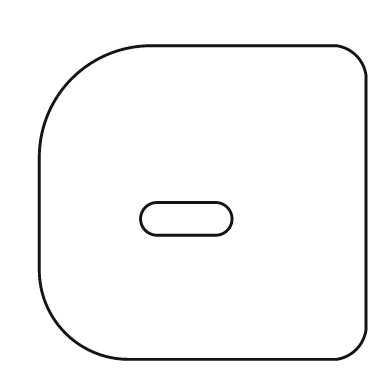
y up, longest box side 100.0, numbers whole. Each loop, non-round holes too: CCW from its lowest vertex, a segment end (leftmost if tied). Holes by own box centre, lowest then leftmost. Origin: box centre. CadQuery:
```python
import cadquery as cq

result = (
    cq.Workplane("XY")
    .moveTo(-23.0, -48.0)
    .lineTo(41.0, -48.0)
    .threePointArc((47.0, -45.0), (50.0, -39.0))
    .lineTo(50.0, 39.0)
    .threePointArc((47.0, 45.0), (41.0, 48.0))
    .lineTo(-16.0, 48.0)
    .threePointArc((-40.0, 38.0), (-50.0, 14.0))
    .lineTo(-50.0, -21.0)
    .threePointArc((-42.0, -40.0), (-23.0, -48.0))
    .close()
    .moveTo(-14.0, -10.0)
    .lineTo(4.0, -10.0)
    .threePointArc((9.0, -5.0), (4.0, 0.0))
    .lineTo(-14.0, 0.0)
    .threePointArc((-19.0, -5.0), (-14.0, -10.0))
    .close()
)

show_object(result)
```